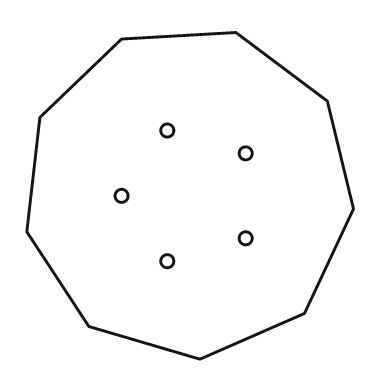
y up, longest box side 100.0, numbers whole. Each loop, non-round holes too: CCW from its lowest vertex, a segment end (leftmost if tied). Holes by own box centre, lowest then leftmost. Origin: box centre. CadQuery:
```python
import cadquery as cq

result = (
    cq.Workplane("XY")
    .moveTo(3.0, -50.0)
    .lineTo(35.0, -36.0)
    .lineTo(50.0, -4.0)
    .lineTo(42.0, 29.0)
    .lineTo(14.0, 50.0)
    .lineTo(-21.0, 48.0)
    .lineTo(-46.0, 24.0)
    .lineTo(-50.0, -11.0)
    .lineTo(-31.0, -40.0)
    .close()
    .moveTo(-7.0, -20.0)
    .circle(2.0)
    .moveTo(17.0, -13.0)
    .circle(2.0)
    .moveTo(-21.0, 0.0)
    .circle(2.0)
    .moveTo(17.0, 13.0)
    .circle(2.0)
    .moveTo(-7.0, 20.0)
    .circle(2.0)
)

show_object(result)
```